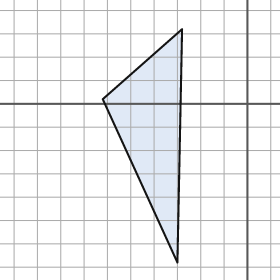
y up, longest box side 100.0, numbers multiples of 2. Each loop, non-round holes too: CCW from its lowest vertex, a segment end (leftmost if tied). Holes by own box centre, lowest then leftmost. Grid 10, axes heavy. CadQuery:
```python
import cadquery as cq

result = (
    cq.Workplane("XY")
    .moveTo(-30.0, -68.0)
    .lineTo(-28.0, 32.0)
    .lineTo(-62.0, 2.0)
    .close()
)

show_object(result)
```